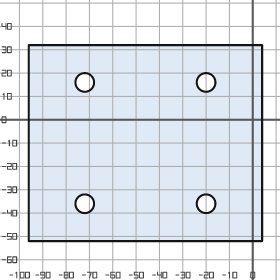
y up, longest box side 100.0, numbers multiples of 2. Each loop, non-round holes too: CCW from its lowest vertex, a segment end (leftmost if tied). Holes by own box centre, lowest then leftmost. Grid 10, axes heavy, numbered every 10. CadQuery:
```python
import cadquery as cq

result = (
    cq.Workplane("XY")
    .moveTo(-96.0, -52.0)
    .lineTo(4.0, -52.0)
    .lineTo(4.0, 32.0)
    .lineTo(-96.0, 32.0)
    .close()
    .moveTo(-72.0, -36.0)
    .circle(4.0)
    .moveTo(-20.0, -36.0)
    .circle(4.0)
    .moveTo(-72.0, 16.0)
    .circle(4.0)
    .moveTo(-20.0, 16.0)
    .circle(4.0)
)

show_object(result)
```